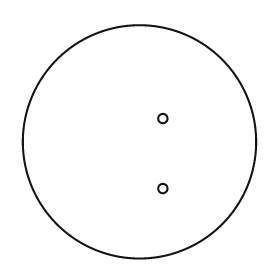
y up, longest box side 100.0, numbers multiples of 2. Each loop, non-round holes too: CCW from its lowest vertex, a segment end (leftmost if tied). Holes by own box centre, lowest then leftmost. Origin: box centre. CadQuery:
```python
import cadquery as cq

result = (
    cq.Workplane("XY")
    .moveTo(0.0, 0.0)
    .circle(50.0)
    .moveTo(10.0, -20.0)
    .circle(2.0)
    .moveTo(10.0, 10.0)
    .circle(2.0)
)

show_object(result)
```